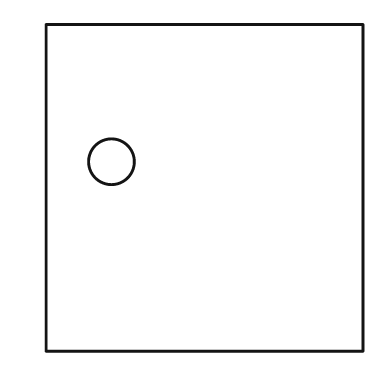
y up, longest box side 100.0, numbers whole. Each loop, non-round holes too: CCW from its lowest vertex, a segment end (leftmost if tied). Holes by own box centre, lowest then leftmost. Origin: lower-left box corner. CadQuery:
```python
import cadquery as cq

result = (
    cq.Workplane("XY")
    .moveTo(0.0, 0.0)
    .lineTo(97.0, 0.0)
    .lineTo(97.0, 100.0)
    .lineTo(0.0, 100.0)
    .close()
    .moveTo(20.0, 58.0)
    .circle(7.0)
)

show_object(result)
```